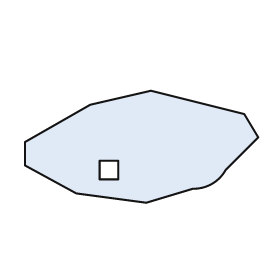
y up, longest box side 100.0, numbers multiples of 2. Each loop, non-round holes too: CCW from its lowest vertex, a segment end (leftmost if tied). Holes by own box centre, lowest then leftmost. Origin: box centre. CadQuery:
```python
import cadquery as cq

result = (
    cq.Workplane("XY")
    .moveTo(2.0, -24.0)
    .lineTo(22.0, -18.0)
    .threePointArc((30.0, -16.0), (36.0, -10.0))
    .lineTo(50.0, 4.0)
    .lineTo(44.0, 14.0)
    .lineTo(4.0, 24.0)
    .lineTo(-22.0, 18.0)
    .lineTo(-50.0, 2.0)
    .lineTo(-50.0, -8.0)
    .lineTo(-28.0, -20.0)
    .close()
    .moveTo(-18.0, -14.0)
    .lineTo(-10.0, -14.0)
    .lineTo(-10.0, -6.0)
    .lineTo(-18.0, -6.0)
    .close()
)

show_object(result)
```